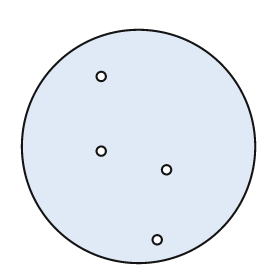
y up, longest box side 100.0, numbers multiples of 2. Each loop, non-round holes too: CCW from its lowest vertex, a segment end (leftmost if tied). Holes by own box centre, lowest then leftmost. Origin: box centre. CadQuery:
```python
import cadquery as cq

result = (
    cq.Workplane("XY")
    .moveTo(0.0, 0.0)
    .circle(50.0)
    .moveTo(8.0, -40.0)
    .circle(2.0)
    .moveTo(12.0, -10.0)
    .circle(2.0)
    .moveTo(-16.0, -2.0)
    .circle(2.0)
    .moveTo(-16.0, 30.0)
    .circle(2.0)
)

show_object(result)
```